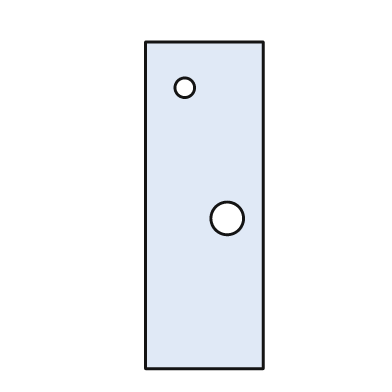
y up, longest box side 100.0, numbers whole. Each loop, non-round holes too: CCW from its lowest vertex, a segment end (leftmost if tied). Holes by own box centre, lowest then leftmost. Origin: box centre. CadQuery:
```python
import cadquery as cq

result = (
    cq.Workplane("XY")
    .moveTo(-18.0, -50.0)
    .lineTo(18.0, -50.0)
    .lineTo(18.0, 50.0)
    .lineTo(-18.0, 50.0)
    .close()
    .moveTo(7.0, -4.0)
    .circle(5.0)
    .moveTo(-6.0, 36.0)
    .circle(3.0)
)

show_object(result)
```